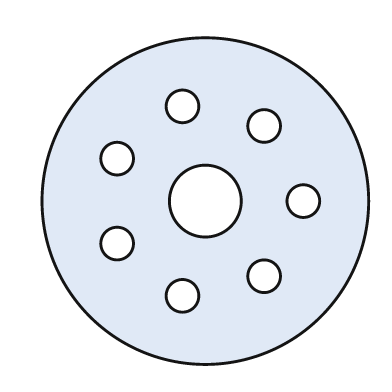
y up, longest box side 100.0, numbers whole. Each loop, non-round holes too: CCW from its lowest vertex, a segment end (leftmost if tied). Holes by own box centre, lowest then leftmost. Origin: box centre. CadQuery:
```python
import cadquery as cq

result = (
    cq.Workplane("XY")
    .moveTo(0.0, 0.0)
    .circle(50.0)
    .moveTo(-7.0, -29.0)
    .circle(5.0)
    .moveTo(18.0, -23.0)
    .circle(5.0)
    .moveTo(-27.0, -13.0)
    .circle(5.0)
    .moveTo(0.0, 0.0)
    .circle(11.0)
    .moveTo(30.0, 0.0)
    .circle(5.0)
    .moveTo(-27.0, 13.0)
    .circle(5.0)
    .moveTo(18.0, 23.0)
    .circle(5.0)
    .moveTo(-7.0, 29.0)
    .circle(5.0)
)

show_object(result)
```